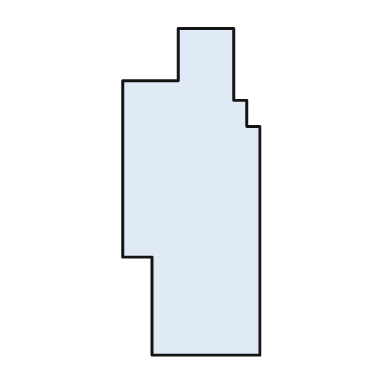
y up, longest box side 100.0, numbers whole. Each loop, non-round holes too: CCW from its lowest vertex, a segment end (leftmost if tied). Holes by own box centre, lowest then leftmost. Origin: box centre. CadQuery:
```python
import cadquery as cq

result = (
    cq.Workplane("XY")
    .moveTo(-12.0, -50.0)
    .lineTo(21.0, -50.0)
    .lineTo(21.0, 20.0)
    .lineTo(17.0, 20.0)
    .lineTo(17.0, 28.0)
    .lineTo(13.0, 28.0)
    .lineTo(13.0, 50.0)
    .lineTo(-4.0, 50.0)
    .lineTo(-4.0, 34.0)
    .lineTo(-21.0, 34.0)
    .lineTo(-21.0, -20.0)
    .lineTo(-12.0, -20.0)
    .close()
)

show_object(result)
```